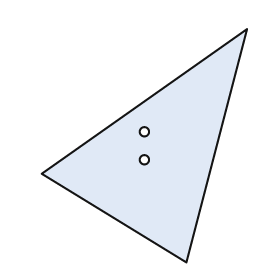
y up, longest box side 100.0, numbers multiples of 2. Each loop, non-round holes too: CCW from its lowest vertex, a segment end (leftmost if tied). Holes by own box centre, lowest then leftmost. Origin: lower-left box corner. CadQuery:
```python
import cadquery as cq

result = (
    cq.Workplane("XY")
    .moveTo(62.0, 0.0)
    .lineTo(88.0, 100.0)
    .lineTo(0.0, 38.0)
    .close()
    .moveTo(44.0, 44.0)
    .circle(2.0)
    .moveTo(44.0, 56.0)
    .circle(2.0)
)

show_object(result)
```